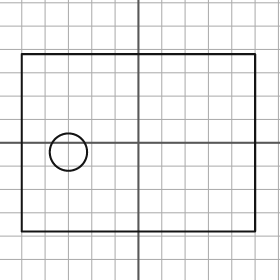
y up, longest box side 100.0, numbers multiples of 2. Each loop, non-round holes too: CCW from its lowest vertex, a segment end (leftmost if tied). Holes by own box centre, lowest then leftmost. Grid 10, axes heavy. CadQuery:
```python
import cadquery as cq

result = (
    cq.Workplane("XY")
    .moveTo(-50.0, -38.0)
    .lineTo(50.0, -38.0)
    .lineTo(50.0, 38.0)
    .lineTo(-50.0, 38.0)
    .close()
    .moveTo(-30.0, -4.0)
    .circle(8.0)
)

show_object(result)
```